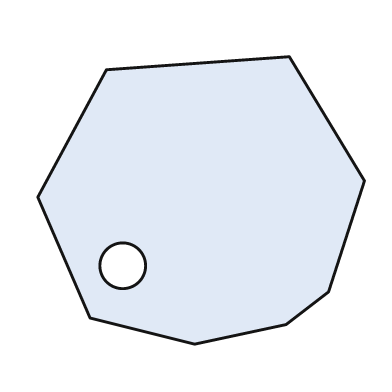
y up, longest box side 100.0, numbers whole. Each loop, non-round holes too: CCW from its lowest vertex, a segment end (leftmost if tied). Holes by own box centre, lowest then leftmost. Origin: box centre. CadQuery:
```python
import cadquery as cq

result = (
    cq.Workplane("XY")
    .moveTo(-2.0, -44.0)
    .lineTo(26.0, -38.0)
    .lineTo(39.0, -28.0)
    .lineTo(50.0, 6.0)
    .lineTo(27.0, 44.0)
    .lineTo(-29.0, 40.0)
    .lineTo(-50.0, 1.0)
    .lineTo(-34.0, -36.0)
    .close()
    .moveTo(-24.0, -20.0)
    .circle(7.0)
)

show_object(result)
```